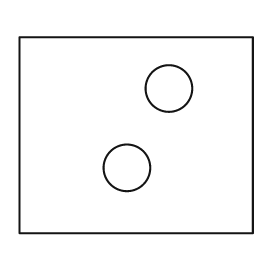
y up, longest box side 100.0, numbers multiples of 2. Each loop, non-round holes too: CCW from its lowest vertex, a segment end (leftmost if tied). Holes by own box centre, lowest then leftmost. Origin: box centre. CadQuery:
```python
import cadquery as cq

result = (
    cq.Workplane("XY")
    .moveTo(-50.0, -42.0)
    .lineTo(50.0, -42.0)
    .lineTo(50.0, 42.0)
    .lineTo(-50.0, 42.0)
    .close()
    .moveTo(-4.0, -14.0)
    .circle(10.0)
    .moveTo(14.0, 20.0)
    .circle(10.0)
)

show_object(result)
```